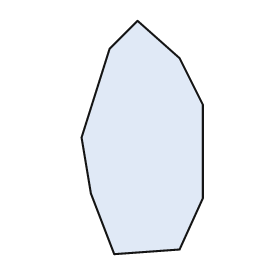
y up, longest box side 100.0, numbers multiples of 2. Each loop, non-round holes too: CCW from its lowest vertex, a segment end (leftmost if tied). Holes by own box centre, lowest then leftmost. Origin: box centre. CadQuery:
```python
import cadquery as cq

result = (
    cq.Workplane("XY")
    .moveTo(-12.0, -50.0)
    .lineTo(16.0, -48.0)
    .lineTo(26.0, -26.0)
    .lineTo(26.0, 14.0)
    .lineTo(16.0, 34.0)
    .lineTo(-2.0, 50.0)
    .lineTo(-14.0, 38.0)
    .lineTo(-26.0, 0.0)
    .lineTo(-22.0, -24.0)
    .close()
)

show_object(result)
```